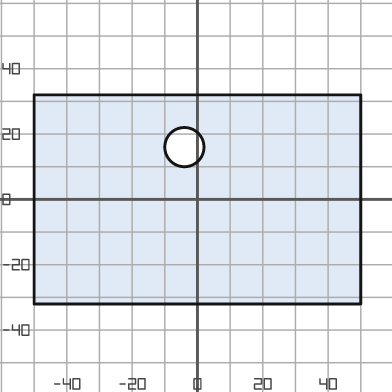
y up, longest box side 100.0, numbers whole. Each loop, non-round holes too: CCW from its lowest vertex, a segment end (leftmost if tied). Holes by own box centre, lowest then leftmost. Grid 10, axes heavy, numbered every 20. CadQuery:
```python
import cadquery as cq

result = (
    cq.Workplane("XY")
    .moveTo(-50.0, -32.0)
    .lineTo(50.0, -32.0)
    .lineTo(50.0, 32.0)
    .lineTo(-50.0, 32.0)
    .close()
    .moveTo(-4.0, 16.0)
    .circle(6.0)
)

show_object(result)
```